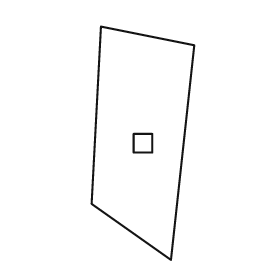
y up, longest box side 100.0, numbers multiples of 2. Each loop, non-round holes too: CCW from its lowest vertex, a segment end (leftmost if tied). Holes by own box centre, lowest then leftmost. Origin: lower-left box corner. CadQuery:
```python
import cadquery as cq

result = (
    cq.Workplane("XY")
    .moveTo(34.0, 0.0)
    .lineTo(44.0, 92.0)
    .lineTo(4.0, 100.0)
    .lineTo(0.0, 24.0)
    .close()
    .moveTo(18.0, 46.0)
    .lineTo(26.0, 46.0)
    .lineTo(26.0, 54.0)
    .lineTo(18.0, 54.0)
    .close()
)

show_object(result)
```